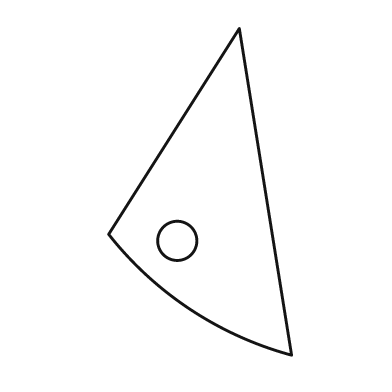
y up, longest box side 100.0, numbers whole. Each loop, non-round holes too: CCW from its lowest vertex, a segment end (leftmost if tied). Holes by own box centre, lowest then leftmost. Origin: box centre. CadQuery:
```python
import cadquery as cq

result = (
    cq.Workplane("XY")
    .moveTo(28.0, -50.0)
    .lineTo(12.0, 50.0)
    .lineTo(-28.0, -13.0)
    .threePointArc((-3.0, -36.0), (28.0, -50.0))
    .close()
    .moveTo(-7.0, -15.0)
    .circle(6.0)
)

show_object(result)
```